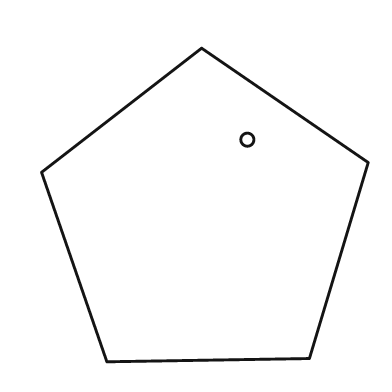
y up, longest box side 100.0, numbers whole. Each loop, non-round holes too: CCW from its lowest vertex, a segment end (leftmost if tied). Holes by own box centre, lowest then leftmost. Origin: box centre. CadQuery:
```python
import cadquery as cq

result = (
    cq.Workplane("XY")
    .moveTo(-30.0, -48.0)
    .lineTo(32.0, -47.0)
    .lineTo(50.0, 13.0)
    .lineTo(-1.0, 48.0)
    .lineTo(-50.0, 10.0)
    .close()
    .moveTo(13.0, 20.0)
    .circle(2.0)
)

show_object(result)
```